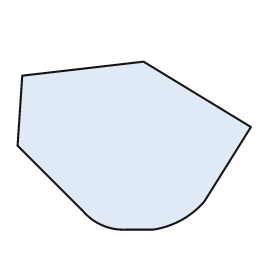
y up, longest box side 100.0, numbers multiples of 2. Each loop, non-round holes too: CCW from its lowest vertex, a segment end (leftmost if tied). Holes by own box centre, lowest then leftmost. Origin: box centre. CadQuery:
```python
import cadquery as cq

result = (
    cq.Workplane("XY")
    .moveTo(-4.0, -36.0)
    .lineTo(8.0, -36.0)
    .threePointArc((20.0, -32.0), (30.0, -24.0))
    .lineTo(50.0, 8.0)
    .lineTo(4.0, 36.0)
    .lineTo(-48.0, 30.0)
    .lineTo(-50.0, 0.0)
    .lineTo(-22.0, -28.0)
    .threePointArc((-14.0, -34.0), (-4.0, -36.0))
    .close()
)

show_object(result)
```